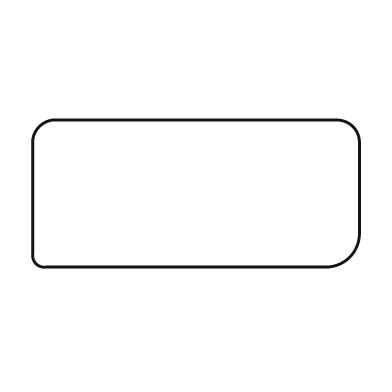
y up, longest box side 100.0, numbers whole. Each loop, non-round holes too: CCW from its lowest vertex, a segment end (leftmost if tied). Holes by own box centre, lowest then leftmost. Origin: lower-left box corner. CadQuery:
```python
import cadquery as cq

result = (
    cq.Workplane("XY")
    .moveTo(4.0, 0.0)
    .lineTo(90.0, 0.0)
    .threePointArc((97.0, 3.0), (100.0, 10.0))
    .lineTo(100.0, 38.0)
    .threePointArc((98.0, 43.0), (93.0, 45.0))
    .lineTo(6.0, 45.0)
    .threePointArc((2.0, 43.0), (0.0, 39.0))
    .lineTo(0.0, 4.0)
    .threePointArc((1.0, 1.0), (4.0, 0.0))
    .close()
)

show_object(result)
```